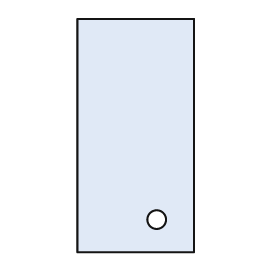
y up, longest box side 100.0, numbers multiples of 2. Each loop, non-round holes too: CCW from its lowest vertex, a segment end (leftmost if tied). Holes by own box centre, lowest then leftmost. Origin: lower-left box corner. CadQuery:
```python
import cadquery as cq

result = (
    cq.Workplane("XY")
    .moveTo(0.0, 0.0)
    .lineTo(50.0, 0.0)
    .lineTo(50.0, 100.0)
    .lineTo(0.0, 100.0)
    .close()
    .moveTo(34.0, 14.0)
    .circle(4.0)
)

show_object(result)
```